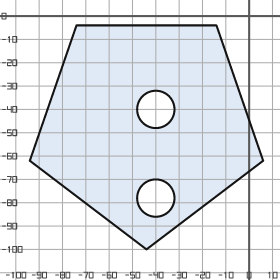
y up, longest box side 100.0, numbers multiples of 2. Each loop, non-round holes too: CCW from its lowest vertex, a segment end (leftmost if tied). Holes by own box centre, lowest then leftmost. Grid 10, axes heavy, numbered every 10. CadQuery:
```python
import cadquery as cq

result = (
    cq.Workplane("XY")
    .moveTo(-44.0, -100.0)
    .lineTo(6.0, -62.0)
    .lineTo(-14.0, -4.0)
    .lineTo(-74.0, -4.0)
    .lineTo(-94.0, -62.0)
    .close()
    .moveTo(-40.0, -78.0)
    .circle(8.0)
    .moveTo(-40.0, -40.0)
    .circle(8.0)
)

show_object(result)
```